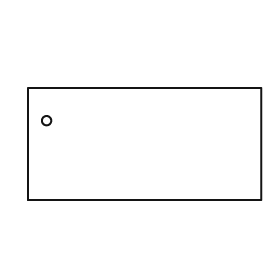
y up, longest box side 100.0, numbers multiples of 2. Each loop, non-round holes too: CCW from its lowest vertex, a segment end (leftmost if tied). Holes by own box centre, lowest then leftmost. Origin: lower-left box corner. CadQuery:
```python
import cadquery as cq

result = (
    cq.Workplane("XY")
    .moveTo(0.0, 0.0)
    .lineTo(100.0, 0.0)
    .lineTo(100.0, 48.0)
    .lineTo(0.0, 48.0)
    .close()
    .moveTo(8.0, 34.0)
    .circle(2.0)
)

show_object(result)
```